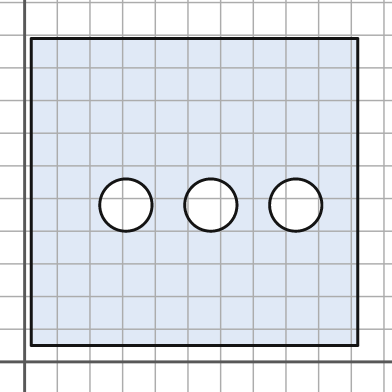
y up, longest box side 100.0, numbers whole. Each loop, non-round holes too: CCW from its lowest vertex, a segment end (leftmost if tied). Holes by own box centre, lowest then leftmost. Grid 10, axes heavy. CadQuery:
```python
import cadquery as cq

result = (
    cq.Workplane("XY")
    .moveTo(2.0, 5.0)
    .lineTo(102.0, 5.0)
    .lineTo(102.0, 99.0)
    .lineTo(2.0, 99.0)
    .close()
    .moveTo(31.0, 48.0)
    .circle(8.0)
    .moveTo(57.0, 48.0)
    .circle(8.0)
    .moveTo(83.0, 48.0)
    .circle(8.0)
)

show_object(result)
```